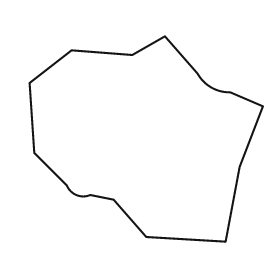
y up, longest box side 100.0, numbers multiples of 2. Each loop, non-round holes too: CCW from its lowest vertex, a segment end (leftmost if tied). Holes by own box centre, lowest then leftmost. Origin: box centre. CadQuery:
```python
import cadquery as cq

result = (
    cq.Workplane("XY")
    .moveTo(34.0, -44.0)
    .lineTo(40.0, -12.0)
    .lineTo(50.0, 14.0)
    .lineTo(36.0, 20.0)
    .threePointArc((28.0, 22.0), (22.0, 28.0))
    .lineTo(8.0, 44.0)
    .lineTo(-6.0, 36.0)
    .lineTo(-32.0, 38.0)
    .lineTo(-50.0, 24.0)
    .lineTo(-48.0, -6.0)
    .lineTo(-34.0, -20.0)
    .threePointArc((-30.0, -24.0), (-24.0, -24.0))
    .lineTo(-14.0, -26.0)
    .lineTo(0.0, -42.0)
    .close()
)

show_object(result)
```